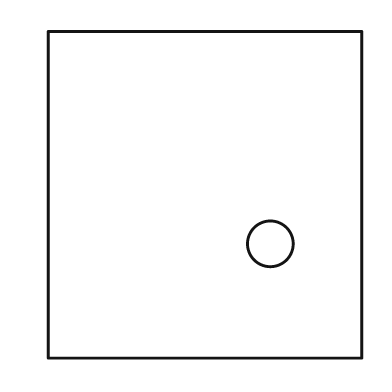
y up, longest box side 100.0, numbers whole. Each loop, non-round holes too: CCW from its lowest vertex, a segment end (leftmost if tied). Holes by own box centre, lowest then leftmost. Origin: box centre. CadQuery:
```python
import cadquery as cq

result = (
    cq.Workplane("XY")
    .moveTo(-48.0, -50.0)
    .lineTo(48.0, -50.0)
    .lineTo(48.0, 50.0)
    .lineTo(-48.0, 50.0)
    .close()
    .moveTo(20.0, -15.0)
    .circle(7.0)
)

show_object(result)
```